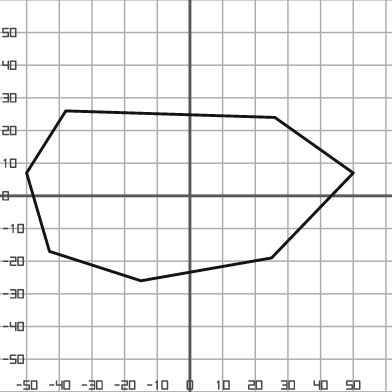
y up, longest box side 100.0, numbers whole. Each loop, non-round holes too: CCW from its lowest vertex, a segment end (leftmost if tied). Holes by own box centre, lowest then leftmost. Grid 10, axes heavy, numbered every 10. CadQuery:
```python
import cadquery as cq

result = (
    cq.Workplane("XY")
    .moveTo(-15.0, -26.0)
    .lineTo(25.0, -19.0)
    .lineTo(50.0, 7.0)
    .lineTo(26.0, 24.0)
    .lineTo(-38.0, 26.0)
    .lineTo(-50.0, 7.0)
    .lineTo(-43.0, -17.0)
    .close()
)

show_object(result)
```